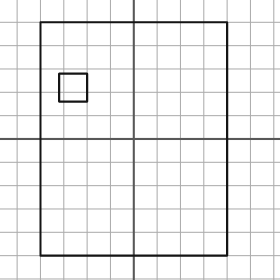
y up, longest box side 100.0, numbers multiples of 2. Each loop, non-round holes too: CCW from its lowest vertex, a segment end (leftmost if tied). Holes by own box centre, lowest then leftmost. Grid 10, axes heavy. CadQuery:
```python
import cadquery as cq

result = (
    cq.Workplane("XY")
    .moveTo(-40.0, -50.0)
    .lineTo(40.0, -50.0)
    .lineTo(40.0, 50.0)
    .lineTo(-40.0, 50.0)
    .close()
    .moveTo(-32.0, 16.0)
    .lineTo(-20.0, 16.0)
    .lineTo(-20.0, 28.0)
    .lineTo(-32.0, 28.0)
    .close()
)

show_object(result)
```